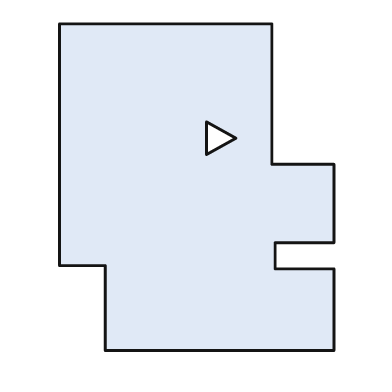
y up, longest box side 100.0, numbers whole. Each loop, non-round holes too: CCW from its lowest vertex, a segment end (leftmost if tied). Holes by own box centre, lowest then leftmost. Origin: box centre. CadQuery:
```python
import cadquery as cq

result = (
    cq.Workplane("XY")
    .moveTo(-28.0, -50.0)
    .lineTo(42.0, -50.0)
    .lineTo(42.0, -25.0)
    .lineTo(24.0, -25.0)
    .lineTo(24.0, -17.0)
    .lineTo(42.0, -17.0)
    .lineTo(42.0, 7.0)
    .lineTo(23.0, 7.0)
    .lineTo(23.0, 50.0)
    .lineTo(-42.0, 50.0)
    .lineTo(-42.0, -24.0)
    .lineTo(-28.0, -24.0)
    .close()
    .moveTo(3.0, 10.0)
    .lineTo(12.0, 15.0)
    .lineTo(3.0, 20.0)
    .close()
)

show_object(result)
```